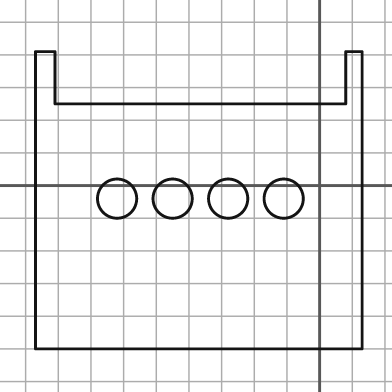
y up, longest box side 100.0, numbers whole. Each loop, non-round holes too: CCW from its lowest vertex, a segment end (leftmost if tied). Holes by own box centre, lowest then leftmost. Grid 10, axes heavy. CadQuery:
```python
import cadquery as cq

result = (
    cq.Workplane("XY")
    .moveTo(-87.0, -50.0)
    .lineTo(13.0, -50.0)
    .lineTo(13.0, 41.0)
    .lineTo(8.0, 41.0)
    .lineTo(8.0, 25.0)
    .lineTo(-81.0, 25.0)
    .lineTo(-81.0, 41.0)
    .lineTo(-87.0, 41.0)
    .close()
    .moveTo(-62.0, -4.0)
    .circle(6.0)
    .moveTo(-45.0, -4.0)
    .circle(6.0)
    .moveTo(-28.0, -4.0)
    .circle(6.0)
    .moveTo(-11.0, -4.0)
    .circle(6.0)
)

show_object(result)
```